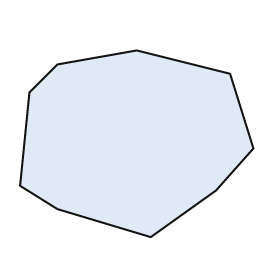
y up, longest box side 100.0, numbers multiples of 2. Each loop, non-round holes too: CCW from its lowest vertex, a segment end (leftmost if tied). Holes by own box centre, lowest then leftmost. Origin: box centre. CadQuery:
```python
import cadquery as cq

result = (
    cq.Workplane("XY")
    .moveTo(6.0, -40.0)
    .lineTo(34.0, -20.0)
    .lineTo(50.0, -2.0)
    .lineTo(40.0, 30.0)
    .lineTo(0.0, 40.0)
    .lineTo(-34.0, 34.0)
    .lineTo(-46.0, 22.0)
    .lineTo(-50.0, -18.0)
    .lineTo(-34.0, -28.0)
    .close()
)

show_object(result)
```